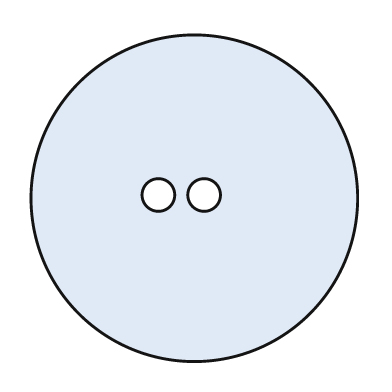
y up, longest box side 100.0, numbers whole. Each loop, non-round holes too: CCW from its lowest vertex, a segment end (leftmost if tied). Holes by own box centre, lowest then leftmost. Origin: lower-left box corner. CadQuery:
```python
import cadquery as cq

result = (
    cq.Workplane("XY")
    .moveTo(50.0, 50.0)
    .circle(50.0)
    .moveTo(39.0, 51.0)
    .circle(5.0)
    .moveTo(53.0, 51.0)
    .circle(5.0)
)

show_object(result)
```